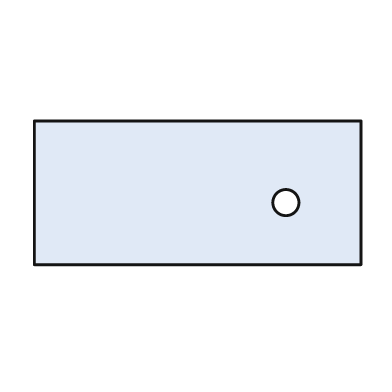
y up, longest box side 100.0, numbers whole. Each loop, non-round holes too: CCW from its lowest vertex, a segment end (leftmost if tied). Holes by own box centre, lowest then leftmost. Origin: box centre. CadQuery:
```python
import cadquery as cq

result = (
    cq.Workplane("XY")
    .moveTo(-50.0, -22.0)
    .lineTo(50.0, -22.0)
    .lineTo(50.0, 22.0)
    .lineTo(-50.0, 22.0)
    .close()
    .moveTo(27.0, -3.0)
    .circle(4.0)
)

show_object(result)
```